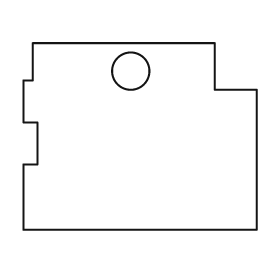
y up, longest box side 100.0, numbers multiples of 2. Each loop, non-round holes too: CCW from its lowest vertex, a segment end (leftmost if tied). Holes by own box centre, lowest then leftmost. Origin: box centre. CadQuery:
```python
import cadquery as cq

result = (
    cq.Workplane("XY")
    .moveTo(-50.0, -40.0)
    .lineTo(50.0, -40.0)
    .lineTo(50.0, 20.0)
    .lineTo(32.0, 20.0)
    .lineTo(32.0, 40.0)
    .lineTo(-46.0, 40.0)
    .lineTo(-46.0, 24.0)
    .lineTo(-50.0, 24.0)
    .lineTo(-50.0, 6.0)
    .lineTo(-44.0, 6.0)
    .lineTo(-44.0, -12.0)
    .lineTo(-50.0, -12.0)
    .close()
    .moveTo(-4.0, 28.0)
    .circle(8.0)
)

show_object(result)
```